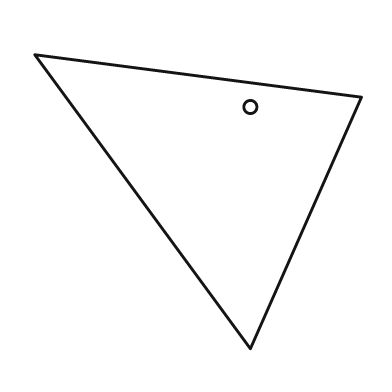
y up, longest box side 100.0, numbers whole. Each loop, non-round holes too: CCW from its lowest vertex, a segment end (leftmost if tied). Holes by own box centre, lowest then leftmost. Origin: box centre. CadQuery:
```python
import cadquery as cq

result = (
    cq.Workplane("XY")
    .moveTo(16.0, -45.0)
    .lineTo(50.0, 32.0)
    .lineTo(-50.0, 45.0)
    .close()
    .moveTo(16.0, 29.0)
    .circle(2.0)
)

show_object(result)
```